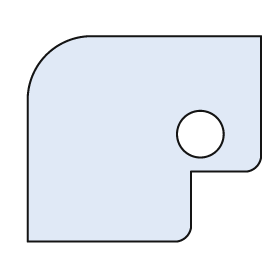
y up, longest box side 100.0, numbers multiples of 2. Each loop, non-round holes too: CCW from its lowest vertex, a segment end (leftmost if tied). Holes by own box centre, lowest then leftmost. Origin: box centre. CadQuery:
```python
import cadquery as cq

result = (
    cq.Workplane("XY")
    .moveTo(-50.0, -44.0)
    .lineTo(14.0, -44.0)
    .threePointArc((18.0, -42.0), (20.0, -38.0))
    .lineTo(20.0, -14.0)
    .lineTo(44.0, -14.0)
    .threePointArc((48.0, -12.0), (50.0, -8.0))
    .lineTo(50.0, 44.0)
    .lineTo(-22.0, 44.0)
    .threePointArc((-42.0, 36.0), (-50.0, 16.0))
    .close()
    .moveTo(24.0, 2.0)
    .circle(10.0)
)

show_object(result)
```